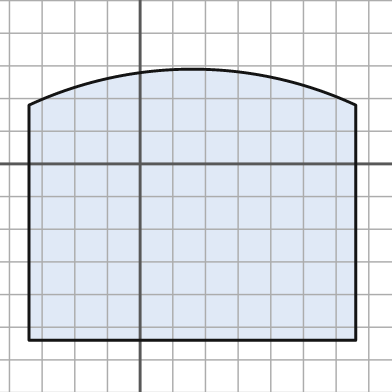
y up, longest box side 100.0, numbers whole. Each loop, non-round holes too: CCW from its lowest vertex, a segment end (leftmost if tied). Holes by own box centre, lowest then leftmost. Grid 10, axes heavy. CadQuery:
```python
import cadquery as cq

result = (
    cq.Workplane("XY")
    .moveTo(-34.0, -54.0)
    .lineTo(66.0, -54.0)
    .lineTo(66.0, 18.0)
    .threePointArc((16.0, 29.0), (-34.0, 18.0))
    .close()
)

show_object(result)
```